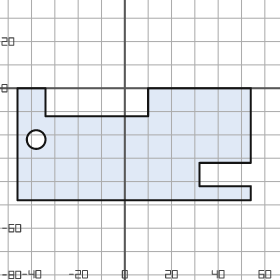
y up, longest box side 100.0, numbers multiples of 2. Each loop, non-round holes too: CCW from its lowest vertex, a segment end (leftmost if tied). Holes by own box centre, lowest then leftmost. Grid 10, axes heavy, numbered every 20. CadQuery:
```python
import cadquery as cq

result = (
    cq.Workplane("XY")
    .moveTo(-46.0, -48.0)
    .lineTo(54.0, -48.0)
    .lineTo(54.0, -42.0)
    .lineTo(32.0, -42.0)
    .lineTo(32.0, -32.0)
    .lineTo(54.0, -32.0)
    .lineTo(54.0, 0.0)
    .lineTo(10.0, 0.0)
    .lineTo(10.0, -12.0)
    .lineTo(-34.0, -12.0)
    .lineTo(-34.0, 0.0)
    .lineTo(-46.0, 0.0)
    .close()
    .moveTo(-38.0, -22.0)
    .circle(4.0)
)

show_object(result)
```